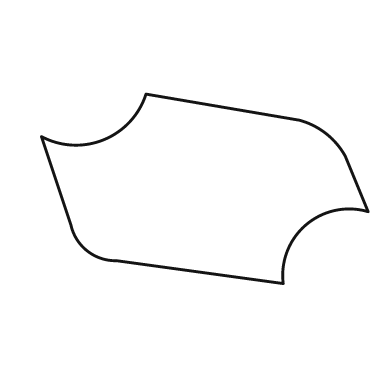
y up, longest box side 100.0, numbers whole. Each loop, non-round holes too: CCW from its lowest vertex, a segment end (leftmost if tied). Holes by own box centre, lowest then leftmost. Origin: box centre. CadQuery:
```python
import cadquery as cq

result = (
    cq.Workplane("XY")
    .moveTo(24.0, -29.0)
    .threePointArc((31.0, -11.0), (50.0, -7.0))
    .lineTo(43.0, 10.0)
    .threePointArc((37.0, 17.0), (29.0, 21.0))
    .lineTo(-18.0, 29.0)
    .threePointArc((-31.0, 15.0), (-50.0, 16.0))
    .lineTo(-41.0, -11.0)
    .threePointArc((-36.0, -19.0), (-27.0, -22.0))
    .close()
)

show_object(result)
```